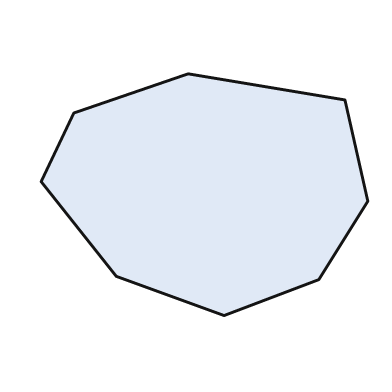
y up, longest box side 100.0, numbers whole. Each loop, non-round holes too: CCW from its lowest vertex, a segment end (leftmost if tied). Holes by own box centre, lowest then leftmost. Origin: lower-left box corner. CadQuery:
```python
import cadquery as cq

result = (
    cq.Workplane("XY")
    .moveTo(56.0, 0.0)
    .lineTo(85.0, 11.0)
    .lineTo(100.0, 35.0)
    .lineTo(93.0, 66.0)
    .lineTo(45.0, 74.0)
    .lineTo(10.0, 62.0)
    .lineTo(0.0, 41.0)
    .lineTo(23.0, 12.0)
    .close()
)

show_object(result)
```